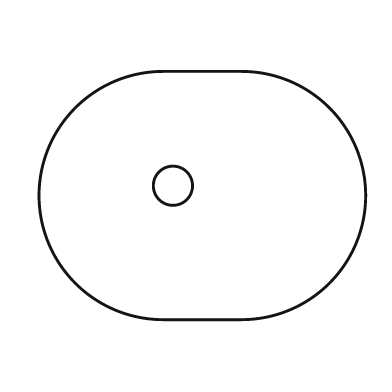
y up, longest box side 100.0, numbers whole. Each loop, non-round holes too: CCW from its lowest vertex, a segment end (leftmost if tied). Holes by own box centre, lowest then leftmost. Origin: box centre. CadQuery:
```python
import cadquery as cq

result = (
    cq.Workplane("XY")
    .moveTo(-12.0, -38.0)
    .lineTo(12.0, -38.0)
    .threePointArc((50.0, 0.0), (12.0, 38.0))
    .lineTo(-12.0, 38.0)
    .threePointArc((-50.0, 0.0), (-12.0, -38.0))
    .close()
    .moveTo(-9.0, 3.0)
    .circle(6.0)
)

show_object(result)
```